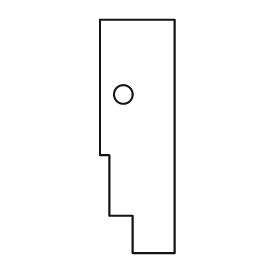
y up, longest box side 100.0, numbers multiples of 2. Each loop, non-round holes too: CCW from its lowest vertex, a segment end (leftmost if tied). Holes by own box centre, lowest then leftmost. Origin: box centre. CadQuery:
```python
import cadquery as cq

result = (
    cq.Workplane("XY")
    .moveTo(-2.0, -50.0)
    .lineTo(16.0, -50.0)
    .lineTo(16.0, 50.0)
    .lineTo(-16.0, 50.0)
    .lineTo(-16.0, -8.0)
    .lineTo(-12.0, -8.0)
    .lineTo(-12.0, -34.0)
    .lineTo(-2.0, -34.0)
    .close()
    .moveTo(-6.0, 18.0)
    .circle(4.0)
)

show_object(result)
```